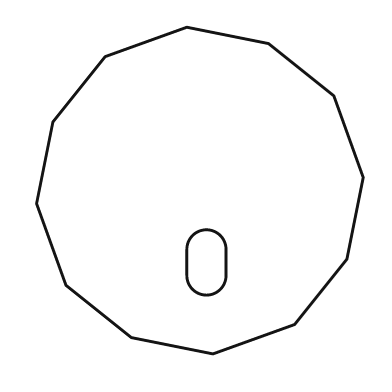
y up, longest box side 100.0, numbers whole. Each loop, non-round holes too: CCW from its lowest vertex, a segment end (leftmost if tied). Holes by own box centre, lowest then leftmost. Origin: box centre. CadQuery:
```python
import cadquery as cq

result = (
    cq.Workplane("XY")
    .moveTo(4.0, -50.0)
    .lineTo(29.0, -41.0)
    .lineTo(45.0, -21.0)
    .lineTo(50.0, 4.0)
    .lineTo(41.0, 29.0)
    .lineTo(21.0, 45.0)
    .lineTo(-4.0, 50.0)
    .lineTo(-29.0, 41.0)
    .lineTo(-45.0, 21.0)
    .lineTo(-50.0, -4.0)
    .lineTo(-41.0, -29.0)
    .lineTo(-21.0, -45.0)
    .close()
    .moveTo(-4.0, -26.0)
    .threePointArc((2.0, -32.0), (8.0, -26.0))
    .lineTo(8.0, -18.0)
    .threePointArc((2.0, -12.0), (-4.0, -18.0))
    .close()
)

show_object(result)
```